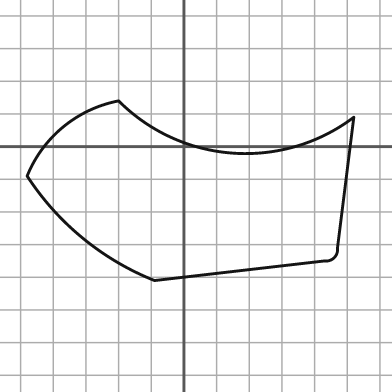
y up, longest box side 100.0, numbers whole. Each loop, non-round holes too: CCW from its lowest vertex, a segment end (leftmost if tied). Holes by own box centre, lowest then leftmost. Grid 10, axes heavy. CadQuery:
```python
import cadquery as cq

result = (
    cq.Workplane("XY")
    .moveTo(-9.0, -41.0)
    .lineTo(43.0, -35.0)
    .threePointArc((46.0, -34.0), (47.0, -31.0))
    .lineTo(52.0, 9.0)
    .threePointArc((15.0, -2.0), (-20.0, 14.0))
    .threePointArc((-37.0, 6.0), (-48.0, -9.0))
    .threePointArc((-31.0, -28.0), (-9.0, -41.0))
    .close()
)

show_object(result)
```